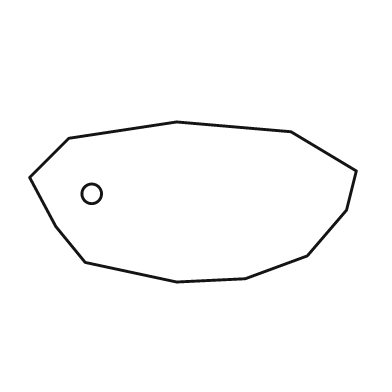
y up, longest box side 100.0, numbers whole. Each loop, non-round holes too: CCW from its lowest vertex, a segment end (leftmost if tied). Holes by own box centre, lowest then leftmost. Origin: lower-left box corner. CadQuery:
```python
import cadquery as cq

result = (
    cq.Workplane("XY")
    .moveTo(45.0, 0.0)
    .lineTo(66.0, 1.0)
    .lineTo(85.0, 8.0)
    .lineTo(97.0, 22.0)
    .lineTo(100.0, 34.0)
    .lineTo(80.0, 46.0)
    .lineTo(45.0, 49.0)
    .lineTo(12.0, 44.0)
    .lineTo(0.0, 32.0)
    .lineTo(8.0, 17.0)
    .lineTo(17.0, 6.0)
    .close()
    .moveTo(19.0, 27.0)
    .circle(3.0)
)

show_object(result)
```